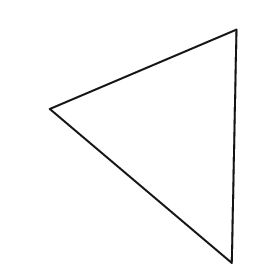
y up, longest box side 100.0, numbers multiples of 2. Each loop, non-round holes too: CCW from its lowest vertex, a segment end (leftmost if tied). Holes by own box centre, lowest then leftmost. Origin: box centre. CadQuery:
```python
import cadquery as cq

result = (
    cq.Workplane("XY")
    .moveTo(38.0, -50.0)
    .lineTo(40.0, 50.0)
    .lineTo(-40.0, 16.0)
    .close()
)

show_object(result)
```